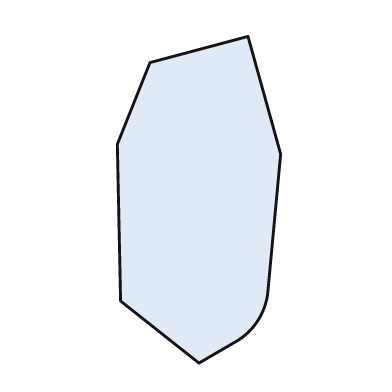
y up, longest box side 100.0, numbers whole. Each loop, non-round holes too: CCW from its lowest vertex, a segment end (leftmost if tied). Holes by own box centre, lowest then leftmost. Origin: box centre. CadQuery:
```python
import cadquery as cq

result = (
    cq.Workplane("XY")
    .moveTo(0.0, -50.0)
    .lineTo(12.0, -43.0)
    .threePointArc((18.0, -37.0), (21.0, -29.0))
    .lineTo(25.0, 14.0)
    .lineTo(15.0, 50.0)
    .lineTo(-15.0, 42.0)
    .lineTo(-25.0, 17.0)
    .lineTo(-24.0, -31.0)
    .close()
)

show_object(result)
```